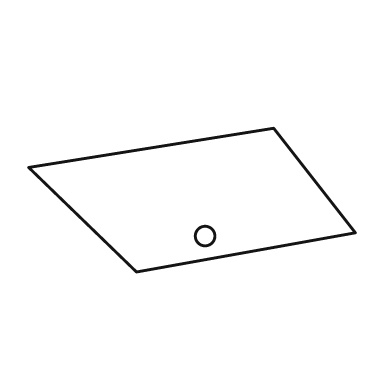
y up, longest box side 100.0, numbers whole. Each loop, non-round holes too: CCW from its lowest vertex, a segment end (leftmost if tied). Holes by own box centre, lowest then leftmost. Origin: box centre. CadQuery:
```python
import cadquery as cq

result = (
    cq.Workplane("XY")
    .moveTo(-17.0, -22.0)
    .lineTo(50.0, -10.0)
    .lineTo(25.0, 22.0)
    .lineTo(-50.0, 10.0)
    .close()
    .moveTo(4.0, -11.0)
    .circle(3.0)
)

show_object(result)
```